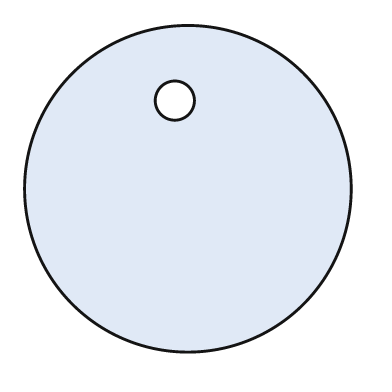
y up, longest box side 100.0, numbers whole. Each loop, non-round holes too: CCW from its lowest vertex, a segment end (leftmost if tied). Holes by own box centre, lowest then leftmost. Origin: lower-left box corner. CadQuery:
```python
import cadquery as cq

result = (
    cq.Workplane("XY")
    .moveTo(50.0, 50.0)
    .circle(50.0)
    .moveTo(46.0, 77.0)
    .circle(6.0)
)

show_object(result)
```